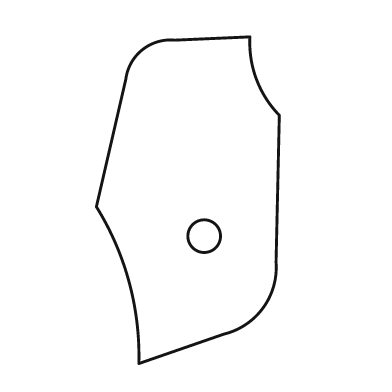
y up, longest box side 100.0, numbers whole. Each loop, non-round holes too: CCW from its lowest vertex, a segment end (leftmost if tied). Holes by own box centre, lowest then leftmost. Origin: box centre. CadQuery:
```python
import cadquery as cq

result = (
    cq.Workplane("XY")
    .moveTo(-15.0, -50.0)
    .lineTo(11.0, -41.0)
    .threePointArc((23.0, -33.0), (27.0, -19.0))
    .lineTo(28.0, 26.0)
    .threePointArc((21.0, 37.0), (19.0, 50.0))
    .lineTo(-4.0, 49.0)
    .threePointArc((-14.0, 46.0), (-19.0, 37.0))
    .lineTo(-28.0, -2.0)
    .threePointArc((-18.0, -25.0), (-15.0, -50.0))
    .close()
    .moveTo(5.0, -11.0)
    .circle(5.0)
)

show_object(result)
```